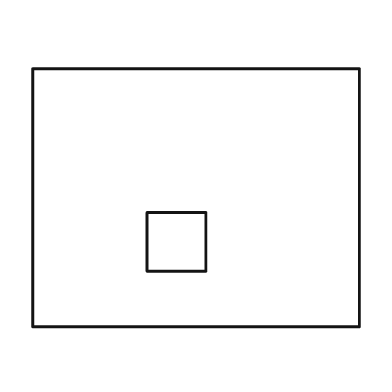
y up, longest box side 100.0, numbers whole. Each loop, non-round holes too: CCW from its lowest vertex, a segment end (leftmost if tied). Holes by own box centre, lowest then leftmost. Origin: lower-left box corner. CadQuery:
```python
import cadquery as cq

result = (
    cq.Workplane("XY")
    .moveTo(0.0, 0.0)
    .lineTo(100.0, 0.0)
    .lineTo(100.0, 79.0)
    .lineTo(0.0, 79.0)
    .close()
    .moveTo(35.0, 17.0)
    .lineTo(53.0, 17.0)
    .lineTo(53.0, 35.0)
    .lineTo(35.0, 35.0)
    .close()
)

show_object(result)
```